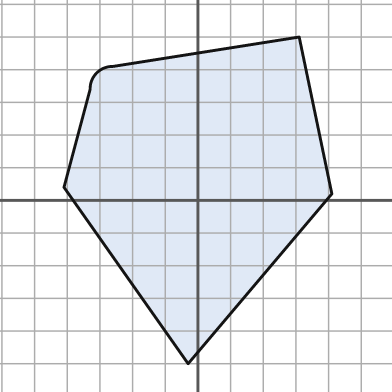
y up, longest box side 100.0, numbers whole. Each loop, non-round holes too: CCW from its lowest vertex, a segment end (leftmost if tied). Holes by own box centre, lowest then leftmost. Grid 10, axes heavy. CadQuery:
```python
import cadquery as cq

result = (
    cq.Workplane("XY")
    .moveTo(-3.0, -50.0)
    .lineTo(41.0, 2.0)
    .lineTo(31.0, 50.0)
    .lineTo(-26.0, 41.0)
    .threePointArc((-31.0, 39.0), (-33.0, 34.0))
    .lineTo(-41.0, 4.0)
    .close()
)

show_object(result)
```